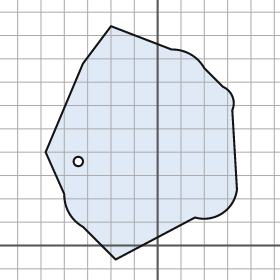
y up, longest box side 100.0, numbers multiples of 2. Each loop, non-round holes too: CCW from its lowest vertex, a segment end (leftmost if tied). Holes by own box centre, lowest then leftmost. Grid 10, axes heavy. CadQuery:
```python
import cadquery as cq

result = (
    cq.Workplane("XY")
    .moveTo(-18.0, -6.0)
    .lineTo(16.0, 12.0)
    .threePointArc((28.0, 14.0), (34.0, 24.0))
    .lineTo(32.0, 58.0)
    .threePointArc((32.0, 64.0), (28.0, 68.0))
    .lineTo(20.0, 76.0)
    .threePointArc((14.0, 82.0), (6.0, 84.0))
    .lineTo(-20.0, 94.0)
    .lineTo(-32.0, 78.0)
    .lineTo(-48.0, 40.0)
    .lineTo(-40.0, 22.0)
    .threePointArc((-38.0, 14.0), (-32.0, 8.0))
    .close()
    .moveTo(-34.0, 36.0)
    .circle(2.0)
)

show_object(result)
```